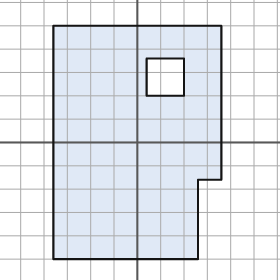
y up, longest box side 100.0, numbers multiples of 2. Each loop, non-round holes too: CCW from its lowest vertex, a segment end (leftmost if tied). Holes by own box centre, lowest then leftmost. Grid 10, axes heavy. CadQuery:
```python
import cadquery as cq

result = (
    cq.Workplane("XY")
    .moveTo(-36.0, -50.0)
    .lineTo(26.0, -50.0)
    .lineTo(26.0, -16.0)
    .lineTo(36.0, -16.0)
    .lineTo(36.0, 50.0)
    .lineTo(-36.0, 50.0)
    .close()
    .moveTo(4.0, 20.0)
    .lineTo(20.0, 20.0)
    .lineTo(20.0, 36.0)
    .lineTo(4.0, 36.0)
    .close()
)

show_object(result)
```